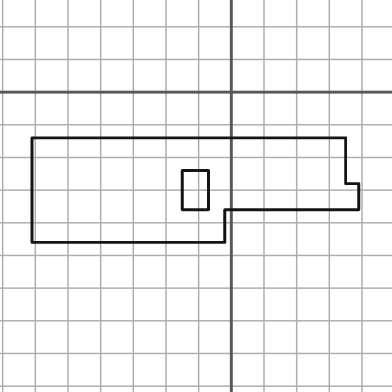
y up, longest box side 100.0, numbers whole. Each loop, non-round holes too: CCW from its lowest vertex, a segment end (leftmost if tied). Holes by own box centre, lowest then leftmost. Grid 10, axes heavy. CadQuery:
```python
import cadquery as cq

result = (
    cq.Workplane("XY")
    .moveTo(-61.0, -46.0)
    .lineTo(-2.0, -46.0)
    .lineTo(-2.0, -36.0)
    .lineTo(39.0, -36.0)
    .lineTo(39.0, -28.0)
    .lineTo(35.0, -28.0)
    .lineTo(35.0, -14.0)
    .lineTo(-61.0, -14.0)
    .close()
    .moveTo(-15.0, -36.0)
    .lineTo(-7.0, -36.0)
    .lineTo(-7.0, -24.0)
    .lineTo(-15.0, -24.0)
    .close()
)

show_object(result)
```